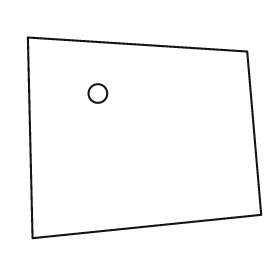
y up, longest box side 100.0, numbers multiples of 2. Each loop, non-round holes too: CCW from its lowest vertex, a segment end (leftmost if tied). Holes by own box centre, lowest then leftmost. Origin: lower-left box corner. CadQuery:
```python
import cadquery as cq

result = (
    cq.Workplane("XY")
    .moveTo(2.0, 0.0)
    .lineTo(100.0, 10.0)
    .lineTo(94.0, 80.0)
    .lineTo(0.0, 86.0)
    .close()
    .moveTo(30.0, 62.0)
    .circle(4.0)
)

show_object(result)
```